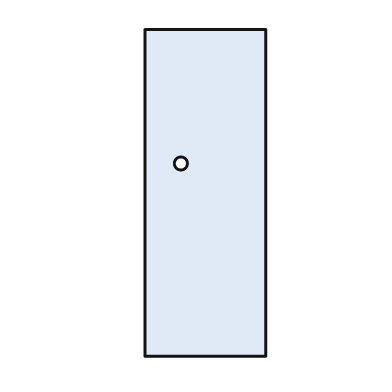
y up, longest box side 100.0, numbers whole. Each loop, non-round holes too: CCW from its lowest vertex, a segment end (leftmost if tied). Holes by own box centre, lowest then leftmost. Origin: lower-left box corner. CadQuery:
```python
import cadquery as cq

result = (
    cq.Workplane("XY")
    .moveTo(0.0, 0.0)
    .lineTo(37.0, 0.0)
    .lineTo(37.0, 100.0)
    .lineTo(0.0, 100.0)
    .close()
    .moveTo(11.0, 59.0)
    .circle(2.0)
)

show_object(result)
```